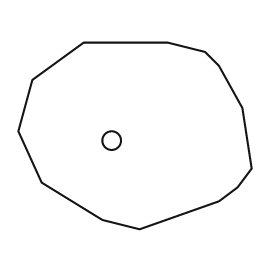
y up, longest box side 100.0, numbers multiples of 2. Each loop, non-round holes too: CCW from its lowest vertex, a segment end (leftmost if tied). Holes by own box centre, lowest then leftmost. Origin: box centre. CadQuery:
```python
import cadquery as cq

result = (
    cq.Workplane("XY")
    .moveTo(2.0, -40.0)
    .lineTo(36.0, -28.0)
    .lineTo(44.0, -22.0)
    .lineTo(50.0, -14.0)
    .lineTo(46.0, 12.0)
    .lineTo(36.0, 30.0)
    .lineTo(30.0, 36.0)
    .lineTo(14.0, 40.0)
    .lineTo(-22.0, 40.0)
    .lineTo(-44.0, 24.0)
    .lineTo(-50.0, 2.0)
    .lineTo(-40.0, -20.0)
    .lineTo(-14.0, -36.0)
    .close()
    .moveTo(-10.0, -2.0)
    .circle(4.0)
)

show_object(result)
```